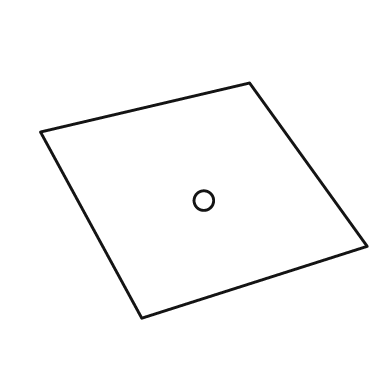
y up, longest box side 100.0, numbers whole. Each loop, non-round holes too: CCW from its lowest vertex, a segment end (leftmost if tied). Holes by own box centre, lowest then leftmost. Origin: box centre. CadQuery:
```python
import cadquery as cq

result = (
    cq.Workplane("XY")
    .moveTo(-19.0, -36.0)
    .lineTo(50.0, -14.0)
    .lineTo(14.0, 36.0)
    .lineTo(-50.0, 21.0)
    .close()
    .moveTo(0.0, 0.0)
    .circle(3.0)
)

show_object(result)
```